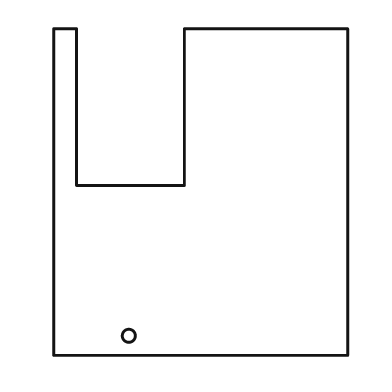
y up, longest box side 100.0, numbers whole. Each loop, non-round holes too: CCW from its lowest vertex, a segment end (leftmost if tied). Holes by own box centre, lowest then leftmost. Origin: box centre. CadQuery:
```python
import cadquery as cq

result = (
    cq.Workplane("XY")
    .moveTo(-45.0, -50.0)
    .lineTo(45.0, -50.0)
    .lineTo(45.0, 50.0)
    .lineTo(-5.0, 50.0)
    .lineTo(-5.0, 2.0)
    .lineTo(-38.0, 2.0)
    .lineTo(-38.0, 50.0)
    .lineTo(-45.0, 50.0)
    .close()
    .moveTo(-22.0, -44.0)
    .circle(2.0)
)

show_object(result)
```